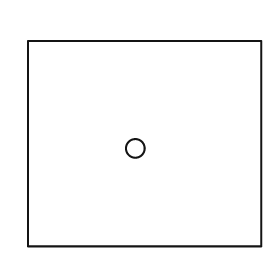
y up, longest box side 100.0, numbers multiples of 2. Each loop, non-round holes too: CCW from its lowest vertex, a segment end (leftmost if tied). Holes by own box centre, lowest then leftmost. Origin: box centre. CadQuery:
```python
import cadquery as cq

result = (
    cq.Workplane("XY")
    .moveTo(-50.0, -44.0)
    .lineTo(50.0, -44.0)
    .lineTo(50.0, 44.0)
    .lineTo(-50.0, 44.0)
    .close()
    .moveTo(-4.0, -2.0)
    .circle(4.0)
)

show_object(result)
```